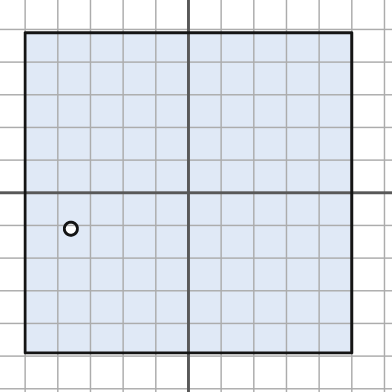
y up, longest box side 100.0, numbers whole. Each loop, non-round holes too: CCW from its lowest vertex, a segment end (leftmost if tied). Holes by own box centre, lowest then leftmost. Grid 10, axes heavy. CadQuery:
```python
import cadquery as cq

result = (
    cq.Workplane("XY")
    .moveTo(-50.0, -49.0)
    .lineTo(50.0, -49.0)
    .lineTo(50.0, 49.0)
    .lineTo(-50.0, 49.0)
    .close()
    .moveTo(-36.0, -11.0)
    .circle(2.0)
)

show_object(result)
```